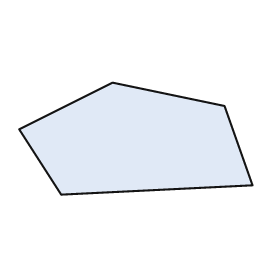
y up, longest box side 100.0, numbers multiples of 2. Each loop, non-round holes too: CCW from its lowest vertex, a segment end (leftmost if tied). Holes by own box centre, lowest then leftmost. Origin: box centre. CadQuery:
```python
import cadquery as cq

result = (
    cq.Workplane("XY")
    .moveTo(-32.0, -24.0)
    .lineTo(50.0, -20.0)
    .lineTo(38.0, 14.0)
    .lineTo(-10.0, 24.0)
    .lineTo(-50.0, 4.0)
    .close()
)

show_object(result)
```